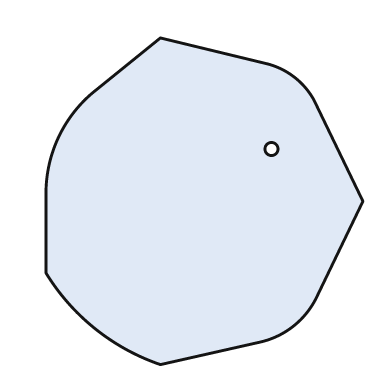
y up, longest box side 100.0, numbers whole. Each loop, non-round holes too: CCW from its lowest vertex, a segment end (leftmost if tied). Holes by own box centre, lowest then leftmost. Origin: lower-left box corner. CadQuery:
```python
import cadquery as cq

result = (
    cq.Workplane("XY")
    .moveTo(35.0, 0.0)
    .lineTo(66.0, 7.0)
    .threePointArc((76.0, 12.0), (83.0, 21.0))
    .lineTo(97.0, 50.0)
    .lineTo(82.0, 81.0)
    .threePointArc((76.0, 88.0), (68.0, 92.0))
    .lineTo(35.0, 100.0)
    .lineTo(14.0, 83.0)
    .threePointArc((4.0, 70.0), (0.0, 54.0))
    .lineTo(0.0, 28.0)
    .threePointArc((15.0, 11.0), (35.0, 0.0))
    .close()
    .moveTo(69.0, 66.0)
    .circle(2.0)
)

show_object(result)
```